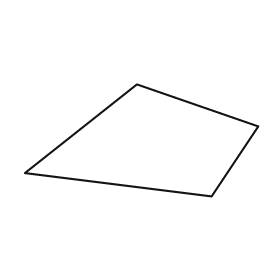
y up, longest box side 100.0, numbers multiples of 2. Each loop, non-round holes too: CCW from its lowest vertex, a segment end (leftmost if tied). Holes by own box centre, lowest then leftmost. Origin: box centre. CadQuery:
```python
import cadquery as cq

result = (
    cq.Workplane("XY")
    .moveTo(30.0, -24.0)
    .lineTo(50.0, 6.0)
    .lineTo(-2.0, 24.0)
    .lineTo(-50.0, -14.0)
    .close()
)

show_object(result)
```